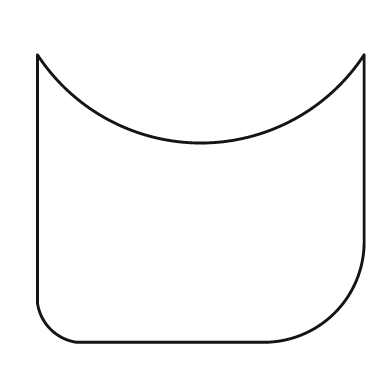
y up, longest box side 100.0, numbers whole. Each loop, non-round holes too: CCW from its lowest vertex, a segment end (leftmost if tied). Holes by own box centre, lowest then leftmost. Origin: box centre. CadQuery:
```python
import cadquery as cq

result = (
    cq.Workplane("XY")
    .moveTo(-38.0, -44.0)
    .lineTo(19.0, -44.0)
    .threePointArc((41.0, -35.0), (50.0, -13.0))
    .lineTo(50.0, 44.0)
    .threePointArc((0.0, 17.0), (-50.0, 44.0))
    .lineTo(-50.0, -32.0)
    .threePointArc((-46.0, -40.0), (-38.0, -44.0))
    .close()
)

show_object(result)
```